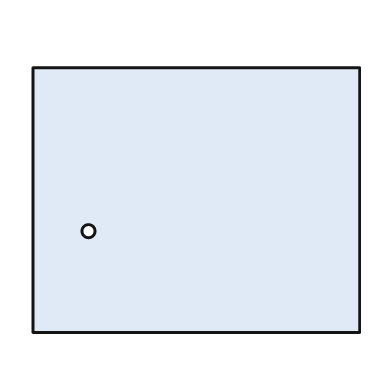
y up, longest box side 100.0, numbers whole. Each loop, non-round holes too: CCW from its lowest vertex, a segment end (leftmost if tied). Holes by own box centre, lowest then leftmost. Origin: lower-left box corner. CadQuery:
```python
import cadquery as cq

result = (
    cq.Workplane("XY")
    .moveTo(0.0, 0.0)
    .lineTo(100.0, 0.0)
    .lineTo(100.0, 81.0)
    .lineTo(0.0, 81.0)
    .close()
    .moveTo(17.0, 31.0)
    .circle(2.0)
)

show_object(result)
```